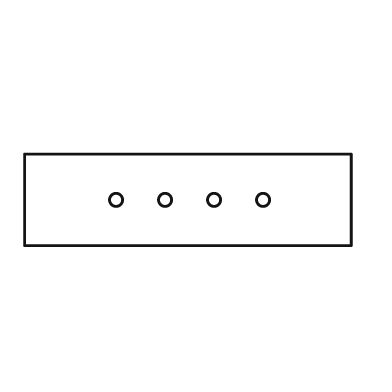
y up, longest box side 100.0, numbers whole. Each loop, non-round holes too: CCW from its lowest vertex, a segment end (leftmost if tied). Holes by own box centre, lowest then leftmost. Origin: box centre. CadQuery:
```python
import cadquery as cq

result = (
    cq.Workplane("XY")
    .moveTo(-50.0, -14.0)
    .lineTo(50.0, -14.0)
    .lineTo(50.0, 14.0)
    .lineTo(-50.0, 14.0)
    .close()
    .moveTo(-22.0, 0.0)
    .circle(2.0)
    .moveTo(-7.0, 0.0)
    .circle(2.0)
    .moveTo(8.0, 0.0)
    .circle(2.0)
    .moveTo(23.0, 0.0)
    .circle(2.0)
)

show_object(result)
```